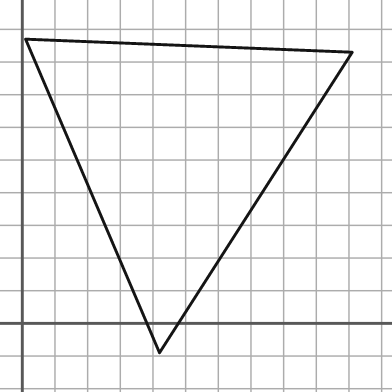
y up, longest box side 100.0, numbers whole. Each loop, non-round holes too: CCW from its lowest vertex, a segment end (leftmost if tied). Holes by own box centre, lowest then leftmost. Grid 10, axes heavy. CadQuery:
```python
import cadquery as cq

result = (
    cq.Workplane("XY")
    .moveTo(42.0, -9.0)
    .lineTo(101.0, 83.0)
    .lineTo(1.0, 87.0)
    .close()
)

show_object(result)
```